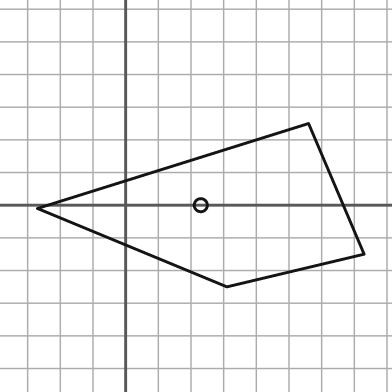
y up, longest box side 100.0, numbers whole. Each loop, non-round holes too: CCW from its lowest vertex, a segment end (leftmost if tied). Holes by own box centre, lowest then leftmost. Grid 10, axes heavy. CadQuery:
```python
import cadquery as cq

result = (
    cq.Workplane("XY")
    .moveTo(31.0, -25.0)
    .lineTo(73.0, -15.0)
    .lineTo(56.0, 25.0)
    .lineTo(-27.0, -1.0)
    .close()
    .moveTo(23.0, 0.0)
    .circle(2.0)
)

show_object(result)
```